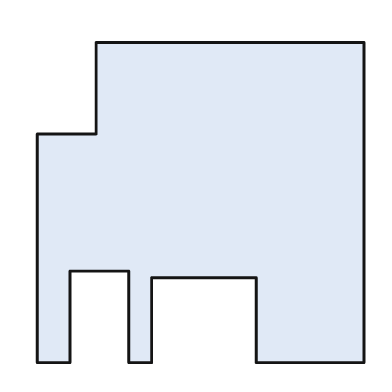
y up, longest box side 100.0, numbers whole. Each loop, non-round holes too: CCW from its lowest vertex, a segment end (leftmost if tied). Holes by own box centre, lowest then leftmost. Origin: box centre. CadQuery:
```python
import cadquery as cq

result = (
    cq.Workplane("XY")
    .moveTo(-50.0, -49.0)
    .lineTo(-40.0, -49.0)
    .lineTo(-40.0, -21.0)
    .lineTo(-22.0, -21.0)
    .lineTo(-22.0, -49.0)
    .lineTo(-15.0, -49.0)
    .lineTo(-15.0, -23.0)
    .lineTo(17.0, -23.0)
    .lineTo(17.0, -49.0)
    .lineTo(50.0, -49.0)
    .lineTo(50.0, 49.0)
    .lineTo(-32.0, 49.0)
    .lineTo(-32.0, 21.0)
    .lineTo(-50.0, 21.0)
    .close()
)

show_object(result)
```